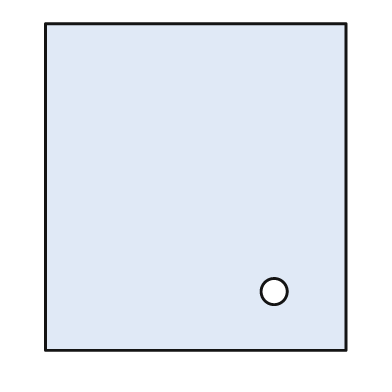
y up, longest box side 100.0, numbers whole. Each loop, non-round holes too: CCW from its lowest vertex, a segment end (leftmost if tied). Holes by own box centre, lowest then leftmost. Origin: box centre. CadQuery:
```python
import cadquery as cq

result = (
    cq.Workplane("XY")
    .moveTo(-46.0, -50.0)
    .lineTo(46.0, -50.0)
    .lineTo(46.0, 50.0)
    .lineTo(-46.0, 50.0)
    .close()
    .moveTo(24.0, -32.0)
    .circle(4.0)
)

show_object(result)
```